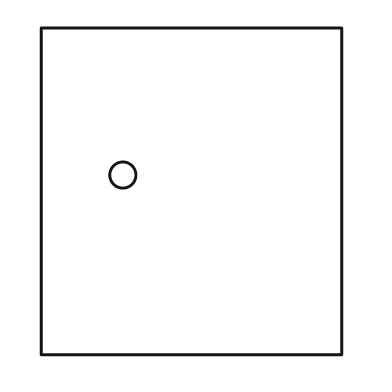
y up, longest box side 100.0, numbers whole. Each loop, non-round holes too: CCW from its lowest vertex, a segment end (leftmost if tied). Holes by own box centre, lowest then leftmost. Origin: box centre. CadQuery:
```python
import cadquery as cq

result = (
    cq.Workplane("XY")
    .moveTo(-46.0, -50.0)
    .lineTo(46.0, -50.0)
    .lineTo(46.0, 50.0)
    .lineTo(-46.0, 50.0)
    .close()
    .moveTo(-21.0, 5.0)
    .circle(4.0)
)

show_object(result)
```